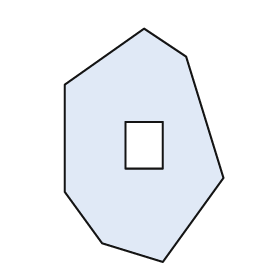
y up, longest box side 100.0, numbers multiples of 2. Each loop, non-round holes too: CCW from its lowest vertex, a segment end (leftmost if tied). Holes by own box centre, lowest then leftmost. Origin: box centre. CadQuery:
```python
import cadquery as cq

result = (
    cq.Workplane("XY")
    .moveTo(8.0, -50.0)
    .lineTo(34.0, -14.0)
    .lineTo(18.0, 38.0)
    .lineTo(0.0, 50.0)
    .lineTo(-34.0, 26.0)
    .lineTo(-34.0, -20.0)
    .lineTo(-18.0, -42.0)
    .close()
    .moveTo(-8.0, -10.0)
    .lineTo(8.0, -10.0)
    .lineTo(8.0, 10.0)
    .lineTo(-8.0, 10.0)
    .close()
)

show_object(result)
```